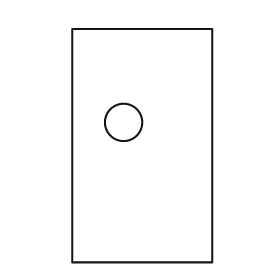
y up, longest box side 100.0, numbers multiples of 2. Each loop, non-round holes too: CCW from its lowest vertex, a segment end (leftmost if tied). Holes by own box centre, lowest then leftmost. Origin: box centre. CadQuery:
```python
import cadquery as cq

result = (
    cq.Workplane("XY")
    .moveTo(-30.0, -50.0)
    .lineTo(30.0, -50.0)
    .lineTo(30.0, 50.0)
    .lineTo(-30.0, 50.0)
    .close()
    .moveTo(-8.0, 10.0)
    .circle(8.0)
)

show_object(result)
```